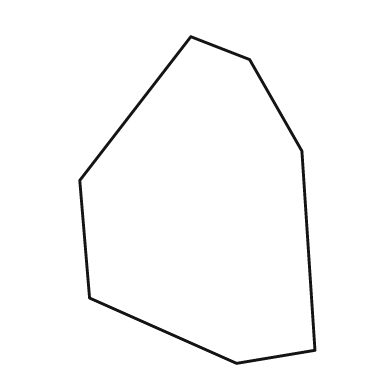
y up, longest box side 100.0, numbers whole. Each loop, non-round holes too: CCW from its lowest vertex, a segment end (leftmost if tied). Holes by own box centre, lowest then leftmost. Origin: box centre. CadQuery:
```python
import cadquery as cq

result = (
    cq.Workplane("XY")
    .moveTo(12.0, -50.0)
    .lineTo(36.0, -46.0)
    .lineTo(32.0, 15.0)
    .lineTo(16.0, 43.0)
    .lineTo(-2.0, 50.0)
    .lineTo(-36.0, 6.0)
    .lineTo(-33.0, -30.0)
    .close()
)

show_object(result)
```